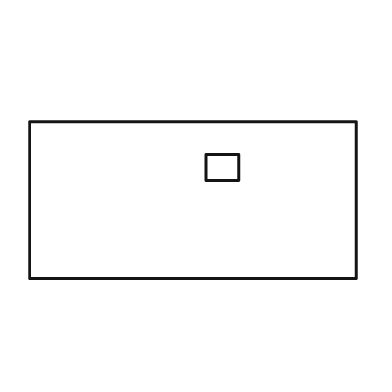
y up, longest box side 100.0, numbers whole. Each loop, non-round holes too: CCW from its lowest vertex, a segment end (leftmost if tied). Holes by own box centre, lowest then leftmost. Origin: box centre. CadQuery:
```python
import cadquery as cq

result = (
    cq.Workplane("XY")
    .moveTo(-50.0, -24.0)
    .lineTo(50.0, -24.0)
    .lineTo(50.0, 24.0)
    .lineTo(-50.0, 24.0)
    .close()
    .moveTo(4.0, 6.0)
    .lineTo(14.0, 6.0)
    .lineTo(14.0, 14.0)
    .lineTo(4.0, 14.0)
    .close()
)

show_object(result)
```